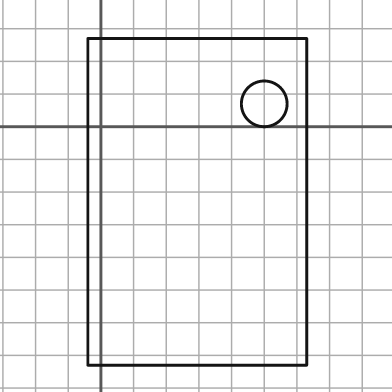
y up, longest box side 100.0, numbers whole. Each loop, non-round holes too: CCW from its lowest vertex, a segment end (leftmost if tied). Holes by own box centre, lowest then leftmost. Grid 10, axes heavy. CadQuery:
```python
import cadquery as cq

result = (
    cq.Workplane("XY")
    .moveTo(-4.0, -73.0)
    .lineTo(63.0, -73.0)
    .lineTo(63.0, 27.0)
    .lineTo(-4.0, 27.0)
    .close()
    .moveTo(50.0, 7.0)
    .circle(7.0)
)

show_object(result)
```